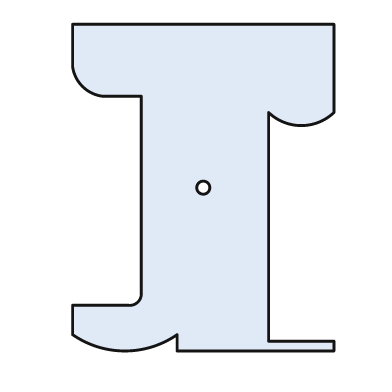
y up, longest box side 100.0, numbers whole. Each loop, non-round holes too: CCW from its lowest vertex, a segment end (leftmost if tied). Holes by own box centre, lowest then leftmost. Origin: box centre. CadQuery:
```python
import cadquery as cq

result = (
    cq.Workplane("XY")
    .moveTo(-8.0, -50.0)
    .lineTo(40.0, -50.0)
    .lineTo(40.0, -47.0)
    .lineTo(20.0, -47.0)
    .lineTo(20.0, 23.0)
    .threePointArc((30.0, 19.0), (40.0, 23.0))
    .lineTo(40.0, 50.0)
    .lineTo(-40.0, 50.0)
    .lineTo(-40.0, 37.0)
    .threePointArc((-37.0, 31.0), (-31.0, 28.0))
    .lineTo(-19.0, 28.0)
    .lineTo(-19.0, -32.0)
    .threePointArc((-20.0, -35.0), (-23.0, -36.0))
    .lineTo(-40.0, -36.0)
    .lineTo(-40.0, -45.0)
    .threePointArc((-24.0, -50.0), (-8.0, -45.0))
    .close()
    .moveTo(0.0, 0.0)
    .circle(2.0)
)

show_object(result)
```